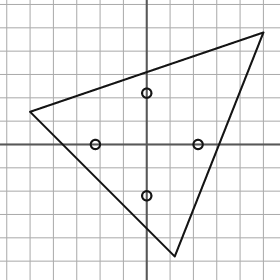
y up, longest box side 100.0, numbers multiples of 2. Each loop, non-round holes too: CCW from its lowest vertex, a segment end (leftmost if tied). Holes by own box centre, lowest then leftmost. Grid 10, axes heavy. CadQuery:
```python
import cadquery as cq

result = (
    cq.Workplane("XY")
    .moveTo(12.0, -48.0)
    .lineTo(50.0, 48.0)
    .lineTo(-50.0, 14.0)
    .close()
    .moveTo(0.0, -22.0)
    .circle(2.0)
    .moveTo(-22.0, 0.0)
    .circle(2.0)
    .moveTo(22.0, 0.0)
    .circle(2.0)
    .moveTo(0.0, 22.0)
    .circle(2.0)
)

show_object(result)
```